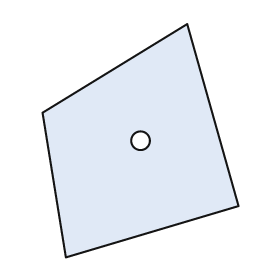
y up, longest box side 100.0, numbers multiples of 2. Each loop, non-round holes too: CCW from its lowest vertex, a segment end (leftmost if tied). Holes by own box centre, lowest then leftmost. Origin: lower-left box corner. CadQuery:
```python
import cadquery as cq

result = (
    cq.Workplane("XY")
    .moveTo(10.0, 0.0)
    .lineTo(84.0, 22.0)
    .lineTo(62.0, 100.0)
    .lineTo(0.0, 62.0)
    .close()
    .moveTo(42.0, 50.0)
    .circle(4.0)
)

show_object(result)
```